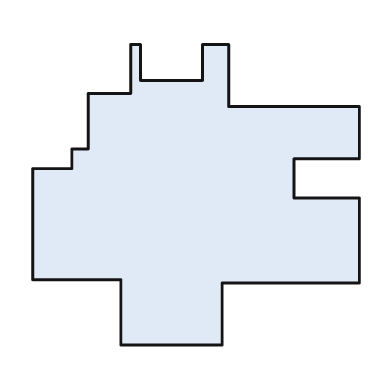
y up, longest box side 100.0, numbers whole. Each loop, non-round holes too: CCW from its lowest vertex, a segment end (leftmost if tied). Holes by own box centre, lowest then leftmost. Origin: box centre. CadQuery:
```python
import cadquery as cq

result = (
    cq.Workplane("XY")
    .moveTo(-23.0, -46.0)
    .lineTo(8.0, -46.0)
    .lineTo(8.0, -27.0)
    .lineTo(50.0, -27.0)
    .lineTo(50.0, -1.0)
    .lineTo(30.0, -1.0)
    .lineTo(30.0, 11.0)
    .lineTo(50.0, 11.0)
    .lineTo(50.0, 27.0)
    .lineTo(10.0, 27.0)
    .lineTo(10.0, 46.0)
    .lineTo(2.0, 46.0)
    .lineTo(2.0, 35.0)
    .lineTo(-17.0, 35.0)
    .lineTo(-17.0, 46.0)
    .lineTo(-20.0, 46.0)
    .lineTo(-20.0, 31.0)
    .lineTo(-33.0, 31.0)
    .lineTo(-33.0, 14.0)
    .lineTo(-38.0, 14.0)
    .lineTo(-38.0, 8.0)
    .lineTo(-50.0, 8.0)
    .lineTo(-50.0, -26.0)
    .lineTo(-23.0, -26.0)
    .close()
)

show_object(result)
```